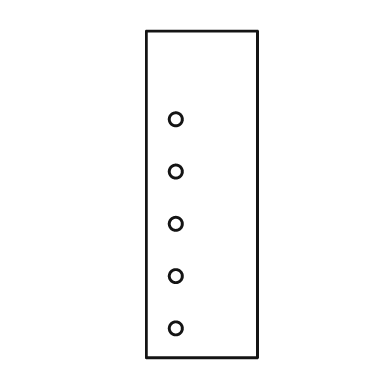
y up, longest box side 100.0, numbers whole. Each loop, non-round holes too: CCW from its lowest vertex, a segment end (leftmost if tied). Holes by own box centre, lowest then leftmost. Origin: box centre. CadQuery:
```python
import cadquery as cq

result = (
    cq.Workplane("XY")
    .moveTo(-17.0, -50.0)
    .lineTo(17.0, -50.0)
    .lineTo(17.0, 50.0)
    .lineTo(-17.0, 50.0)
    .close()
    .moveTo(-8.0, -41.0)
    .circle(2.0)
    .moveTo(-8.0, -25.0)
    .circle(2.0)
    .moveTo(-8.0, -9.0)
    .circle(2.0)
    .moveTo(-8.0, 7.0)
    .circle(2.0)
    .moveTo(-8.0, 23.0)
    .circle(2.0)
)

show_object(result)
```